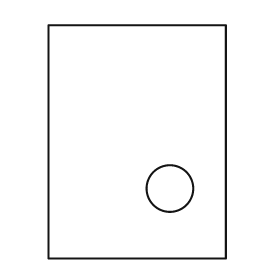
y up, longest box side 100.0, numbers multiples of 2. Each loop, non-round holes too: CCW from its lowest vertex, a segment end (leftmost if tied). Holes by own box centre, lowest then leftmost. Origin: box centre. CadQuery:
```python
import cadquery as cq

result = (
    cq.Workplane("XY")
    .moveTo(-38.0, -50.0)
    .lineTo(38.0, -50.0)
    .lineTo(38.0, 50.0)
    .lineTo(-38.0, 50.0)
    .close()
    .moveTo(14.0, -20.0)
    .circle(10.0)
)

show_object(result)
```